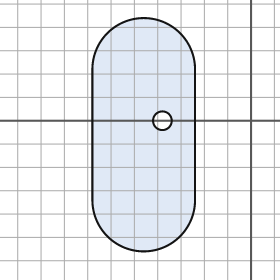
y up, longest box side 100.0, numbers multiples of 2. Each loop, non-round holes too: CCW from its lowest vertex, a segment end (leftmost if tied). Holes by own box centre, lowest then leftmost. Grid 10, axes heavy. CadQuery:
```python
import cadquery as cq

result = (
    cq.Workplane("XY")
    .moveTo(-68.0, -34.0)
    .threePointArc((-46.0, -56.0), (-24.0, -34.0))
    .lineTo(-24.0, 22.0)
    .threePointArc((-46.0, 44.0), (-68.0, 22.0))
    .close()
    .moveTo(-38.0, 0.0)
    .circle(4.0)
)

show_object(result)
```